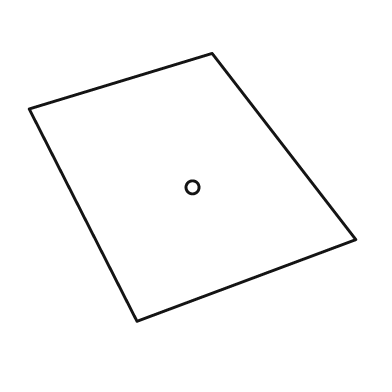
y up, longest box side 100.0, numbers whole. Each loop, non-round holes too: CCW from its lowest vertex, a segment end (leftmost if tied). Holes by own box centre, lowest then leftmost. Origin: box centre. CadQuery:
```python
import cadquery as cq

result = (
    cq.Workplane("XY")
    .moveTo(-17.0, -41.0)
    .lineTo(50.0, -16.0)
    .lineTo(6.0, 41.0)
    .lineTo(-50.0, 24.0)
    .close()
    .moveTo(0.0, 0.0)
    .circle(2.0)
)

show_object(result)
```